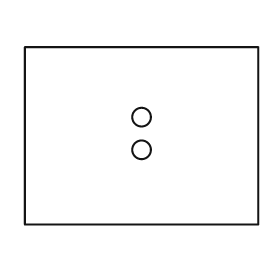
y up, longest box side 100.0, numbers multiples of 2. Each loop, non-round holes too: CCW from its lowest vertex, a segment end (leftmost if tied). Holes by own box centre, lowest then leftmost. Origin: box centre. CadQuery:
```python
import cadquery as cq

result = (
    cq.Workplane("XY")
    .moveTo(-50.0, -38.0)
    .lineTo(50.0, -38.0)
    .lineTo(50.0, 38.0)
    .lineTo(-50.0, 38.0)
    .close()
    .moveTo(0.0, -6.0)
    .circle(4.0)
    .moveTo(0.0, 8.0)
    .circle(4.0)
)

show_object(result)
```